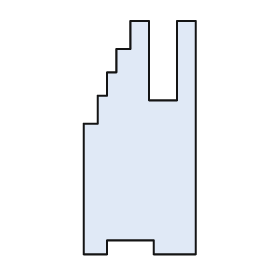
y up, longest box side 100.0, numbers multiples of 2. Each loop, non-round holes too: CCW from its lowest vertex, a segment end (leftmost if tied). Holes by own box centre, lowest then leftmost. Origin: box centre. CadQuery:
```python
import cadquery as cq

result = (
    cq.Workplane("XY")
    .moveTo(-24.0, -50.0)
    .lineTo(-14.0, -50.0)
    .lineTo(-14.0, -44.0)
    .lineTo(6.0, -44.0)
    .lineTo(6.0, -50.0)
    .lineTo(24.0, -50.0)
    .lineTo(24.0, 50.0)
    .lineTo(16.0, 50.0)
    .lineTo(16.0, 16.0)
    .lineTo(4.0, 16.0)
    .lineTo(4.0, 50.0)
    .lineTo(-4.0, 50.0)
    .lineTo(-4.0, 38.0)
    .lineTo(-10.0, 38.0)
    .lineTo(-10.0, 28.0)
    .lineTo(-14.0, 28.0)
    .lineTo(-14.0, 18.0)
    .lineTo(-18.0, 18.0)
    .lineTo(-18.0, 6.0)
    .lineTo(-24.0, 6.0)
    .close()
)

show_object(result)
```